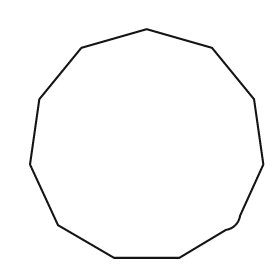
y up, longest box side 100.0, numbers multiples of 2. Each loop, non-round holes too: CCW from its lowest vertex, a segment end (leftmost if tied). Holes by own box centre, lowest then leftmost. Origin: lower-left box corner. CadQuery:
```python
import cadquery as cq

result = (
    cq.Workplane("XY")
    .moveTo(36.0, 0.0)
    .lineTo(64.0, 0.0)
    .lineTo(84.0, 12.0)
    .threePointArc((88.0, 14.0), (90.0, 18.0))
    .lineTo(100.0, 40.0)
    .lineTo(96.0, 68.0)
    .lineTo(78.0, 90.0)
    .lineTo(50.0, 98.0)
    .lineTo(22.0, 90.0)
    .lineTo(4.0, 68.0)
    .lineTo(0.0, 40.0)
    .lineTo(12.0, 14.0)
    .close()
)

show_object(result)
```